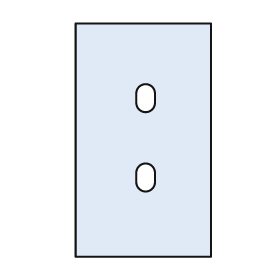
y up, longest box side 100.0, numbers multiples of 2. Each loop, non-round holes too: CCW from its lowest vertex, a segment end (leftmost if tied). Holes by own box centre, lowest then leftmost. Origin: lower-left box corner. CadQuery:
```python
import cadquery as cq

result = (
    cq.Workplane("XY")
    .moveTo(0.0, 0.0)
    .lineTo(58.0, 0.0)
    .lineTo(58.0, 100.0)
    .lineTo(0.0, 100.0)
    .close()
    .moveTo(26.0, 32.0)
    .threePointArc((30.0, 28.0), (34.0, 32.0))
    .lineTo(34.0, 36.0)
    .threePointArc((30.0, 40.0), (26.0, 36.0))
    .close()
    .moveTo(26.0, 66.0)
    .threePointArc((30.0, 62.0), (34.0, 66.0))
    .lineTo(34.0, 70.0)
    .threePointArc((30.0, 74.0), (26.0, 70.0))
    .close()
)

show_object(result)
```